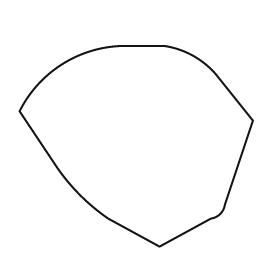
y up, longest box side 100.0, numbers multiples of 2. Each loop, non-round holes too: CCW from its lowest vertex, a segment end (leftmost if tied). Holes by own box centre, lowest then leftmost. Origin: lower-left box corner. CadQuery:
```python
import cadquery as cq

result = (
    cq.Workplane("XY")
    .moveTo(60.0, 0.0)
    .lineTo(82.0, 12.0)
    .threePointArc((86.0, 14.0), (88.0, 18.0))
    .lineTo(100.0, 54.0)
    .lineTo(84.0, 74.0)
    .threePointArc((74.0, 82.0), (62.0, 86.0))
    .lineTo(44.0, 86.0)
    .threePointArc((18.0, 78.0), (0.0, 58.0))
    .lineTo(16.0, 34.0)
    .threePointArc((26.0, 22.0), (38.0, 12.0))
    .close()
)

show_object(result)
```